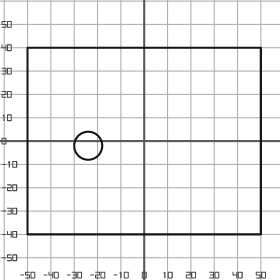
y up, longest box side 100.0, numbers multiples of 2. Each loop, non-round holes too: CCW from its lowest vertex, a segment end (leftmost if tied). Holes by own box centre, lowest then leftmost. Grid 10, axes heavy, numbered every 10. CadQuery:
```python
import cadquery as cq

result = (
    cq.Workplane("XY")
    .moveTo(-50.0, -40.0)
    .lineTo(50.0, -40.0)
    .lineTo(50.0, 40.0)
    .lineTo(-50.0, 40.0)
    .close()
    .moveTo(-24.0, -2.0)
    .circle(6.0)
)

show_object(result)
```